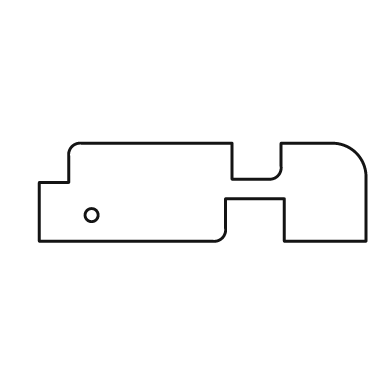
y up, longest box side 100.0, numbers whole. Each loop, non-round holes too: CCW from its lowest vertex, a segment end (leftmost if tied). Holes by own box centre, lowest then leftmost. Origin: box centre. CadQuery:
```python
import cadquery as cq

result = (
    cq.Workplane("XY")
    .moveTo(-50.0, -15.0)
    .lineTo(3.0, -15.0)
    .threePointArc((6.0, -14.0), (7.0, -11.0))
    .lineTo(7.0, -2.0)
    .lineTo(25.0, -2.0)
    .lineTo(25.0, -15.0)
    .lineTo(50.0, -15.0)
    .lineTo(50.0, 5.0)
    .threePointArc((47.0, 12.0), (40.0, 15.0))
    .lineTo(24.0, 15.0)
    .lineTo(24.0, 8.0)
    .threePointArc((23.0, 5.0), (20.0, 4.0))
    .lineTo(9.0, 4.0)
    .lineTo(9.0, 15.0)
    .lineTo(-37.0, 15.0)
    .threePointArc((-40.0, 14.0), (-41.0, 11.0))
    .lineTo(-41.0, 3.0)
    .lineTo(-50.0, 3.0)
    .close()
    .moveTo(-34.0, -7.0)
    .circle(2.0)
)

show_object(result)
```